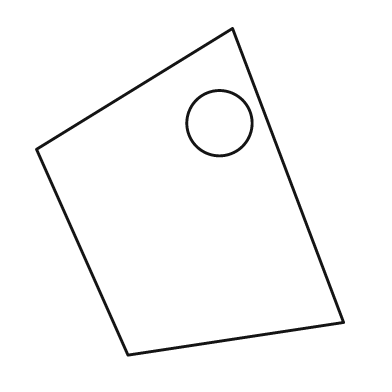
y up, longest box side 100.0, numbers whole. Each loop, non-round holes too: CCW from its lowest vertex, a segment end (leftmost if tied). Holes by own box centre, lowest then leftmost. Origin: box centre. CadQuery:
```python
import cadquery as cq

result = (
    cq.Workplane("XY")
    .moveTo(-19.0, -50.0)
    .lineTo(47.0, -40.0)
    .lineTo(13.0, 50.0)
    .lineTo(-47.0, 13.0)
    .close()
    .moveTo(9.0, 21.0)
    .circle(10.0)
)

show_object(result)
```